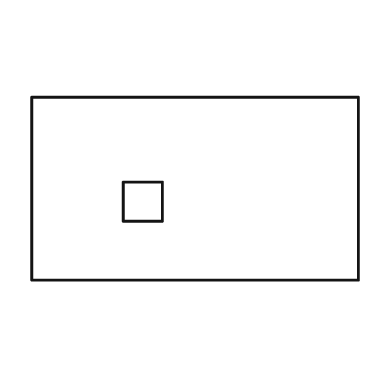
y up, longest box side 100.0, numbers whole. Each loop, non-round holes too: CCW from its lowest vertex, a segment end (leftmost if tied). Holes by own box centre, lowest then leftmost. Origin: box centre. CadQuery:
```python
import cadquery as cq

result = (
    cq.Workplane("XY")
    .moveTo(-50.0, -28.0)
    .lineTo(50.0, -28.0)
    .lineTo(50.0, 28.0)
    .lineTo(-50.0, 28.0)
    .close()
    .moveTo(-22.0, -10.0)
    .lineTo(-10.0, -10.0)
    .lineTo(-10.0, 2.0)
    .lineTo(-22.0, 2.0)
    .close()
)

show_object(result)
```